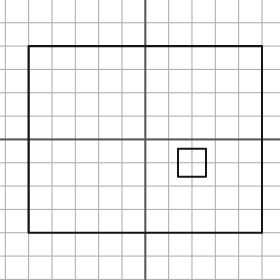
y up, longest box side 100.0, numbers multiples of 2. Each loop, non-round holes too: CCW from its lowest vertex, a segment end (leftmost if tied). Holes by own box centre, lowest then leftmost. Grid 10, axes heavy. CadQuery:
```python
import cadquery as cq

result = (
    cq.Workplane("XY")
    .moveTo(-50.0, -40.0)
    .lineTo(50.0, -40.0)
    .lineTo(50.0, 40.0)
    .lineTo(-50.0, 40.0)
    .close()
    .moveTo(14.0, -16.0)
    .lineTo(26.0, -16.0)
    .lineTo(26.0, -4.0)
    .lineTo(14.0, -4.0)
    .close()
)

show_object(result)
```